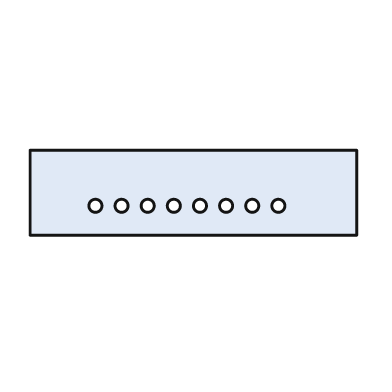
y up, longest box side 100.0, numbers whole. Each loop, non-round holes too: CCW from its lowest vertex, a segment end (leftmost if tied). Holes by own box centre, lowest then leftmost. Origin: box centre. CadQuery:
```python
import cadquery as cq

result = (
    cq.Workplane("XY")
    .moveTo(-50.0, -13.0)
    .lineTo(50.0, -13.0)
    .lineTo(50.0, 13.0)
    .lineTo(-50.0, 13.0)
    .close()
    .moveTo(-30.0, -4.0)
    .circle(2.0)
    .moveTo(-22.0, -4.0)
    .circle(2.0)
    .moveTo(-14.0, -4.0)
    .circle(2.0)
    .moveTo(-6.0, -4.0)
    .circle(2.0)
    .moveTo(2.0, -4.0)
    .circle(2.0)
    .moveTo(10.0, -4.0)
    .circle(2.0)
    .moveTo(18.0, -4.0)
    .circle(2.0)
    .moveTo(26.0, -4.0)
    .circle(2.0)
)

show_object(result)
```